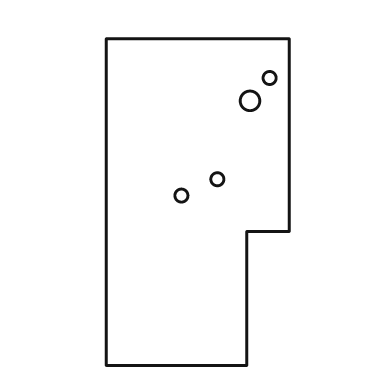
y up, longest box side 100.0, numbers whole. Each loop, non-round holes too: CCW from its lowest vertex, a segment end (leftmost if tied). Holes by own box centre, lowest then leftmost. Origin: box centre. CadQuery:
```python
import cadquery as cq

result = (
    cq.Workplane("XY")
    .moveTo(-28.0, -50.0)
    .lineTo(15.0, -50.0)
    .lineTo(15.0, -9.0)
    .lineTo(28.0, -9.0)
    .lineTo(28.0, 50.0)
    .lineTo(-28.0, 50.0)
    .close()
    .moveTo(-5.0, 2.0)
    .circle(2.0)
    .moveTo(6.0, 7.0)
    .circle(2.0)
    .moveTo(16.0, 31.0)
    .circle(3.0)
    .moveTo(22.0, 38.0)
    .circle(2.0)
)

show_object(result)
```